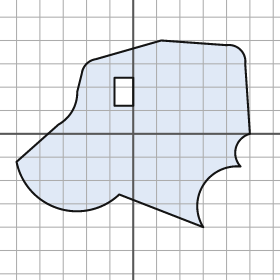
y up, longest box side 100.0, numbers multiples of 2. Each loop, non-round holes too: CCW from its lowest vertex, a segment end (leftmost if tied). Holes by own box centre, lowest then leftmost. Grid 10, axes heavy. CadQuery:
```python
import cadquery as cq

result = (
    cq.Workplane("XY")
    .moveTo(30.0, -40.0)
    .threePointArc((30.0, -22.0), (46.0, -14.0))
    .threePointArc((44.0, -6.0), (50.0, 0.0))
    .lineTo(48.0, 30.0)
    .threePointArc((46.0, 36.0), (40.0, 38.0))
    .lineTo(12.0, 40.0)
    .lineTo(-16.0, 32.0)
    .threePointArc((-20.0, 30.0), (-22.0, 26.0))
    .lineTo(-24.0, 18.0)
    .threePointArc((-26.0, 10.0), (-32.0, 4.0))
    .lineTo(-50.0, -12.0)
    .threePointArc((-32.0, -32.0), (-6.0, -26.0))
    .close()
    .moveTo(-8.0, 12.0)
    .lineTo(0.0, 12.0)
    .lineTo(0.0, 24.0)
    .lineTo(-8.0, 24.0)
    .close()
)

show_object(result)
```